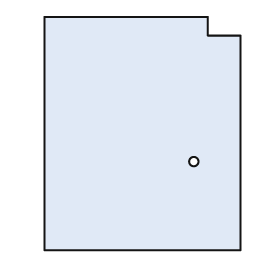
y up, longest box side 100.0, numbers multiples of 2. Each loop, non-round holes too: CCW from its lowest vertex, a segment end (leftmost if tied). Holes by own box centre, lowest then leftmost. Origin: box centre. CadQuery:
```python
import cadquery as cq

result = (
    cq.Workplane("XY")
    .moveTo(-42.0, -50.0)
    .lineTo(42.0, -50.0)
    .lineTo(42.0, 42.0)
    .lineTo(28.0, 42.0)
    .lineTo(28.0, 50.0)
    .lineTo(-42.0, 50.0)
    .close()
    .moveTo(22.0, -12.0)
    .circle(2.0)
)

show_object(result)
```